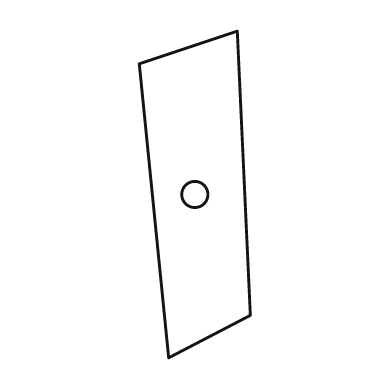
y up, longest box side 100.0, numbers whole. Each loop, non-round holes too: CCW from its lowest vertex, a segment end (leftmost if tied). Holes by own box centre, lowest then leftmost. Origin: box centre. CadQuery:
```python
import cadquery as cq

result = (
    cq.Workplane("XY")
    .moveTo(-8.0, -50.0)
    .lineTo(17.0, -37.0)
    .lineTo(13.0, 50.0)
    .lineTo(-17.0, 40.0)
    .close()
    .moveTo(0.0, 0.0)
    .circle(4.0)
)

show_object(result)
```